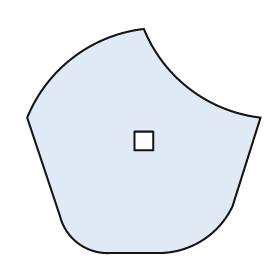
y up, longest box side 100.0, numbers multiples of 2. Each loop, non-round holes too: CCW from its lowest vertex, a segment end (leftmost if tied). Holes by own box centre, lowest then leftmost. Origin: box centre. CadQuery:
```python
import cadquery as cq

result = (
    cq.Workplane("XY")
    .moveTo(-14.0, -48.0)
    .lineTo(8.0, -48.0)
    .threePointArc((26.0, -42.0), (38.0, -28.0))
    .lineTo(50.0, 10.0)
    .threePointArc((20.0, 22.0), (0.0, 48.0))
    .threePointArc((-30.0, 36.0), (-50.0, 10.0))
    .lineTo(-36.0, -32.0)
    .threePointArc((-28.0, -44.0), (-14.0, -48.0))
    .close()
    .moveTo(-4.0, -4.0)
    .lineTo(4.0, -4.0)
    .lineTo(4.0, 4.0)
    .lineTo(-4.0, 4.0)
    .close()
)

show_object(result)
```